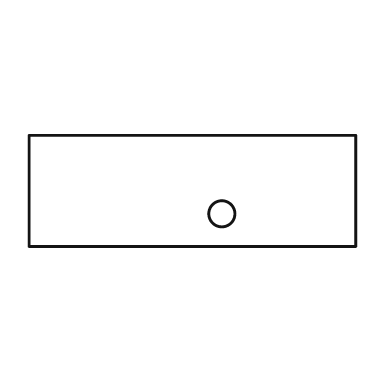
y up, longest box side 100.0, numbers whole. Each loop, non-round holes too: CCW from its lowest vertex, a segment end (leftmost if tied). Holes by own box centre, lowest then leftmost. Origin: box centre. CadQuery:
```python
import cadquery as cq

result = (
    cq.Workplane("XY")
    .moveTo(-50.0, -17.0)
    .lineTo(50.0, -17.0)
    .lineTo(50.0, 17.0)
    .lineTo(-50.0, 17.0)
    .close()
    .moveTo(9.0, -7.0)
    .circle(4.0)
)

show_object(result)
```